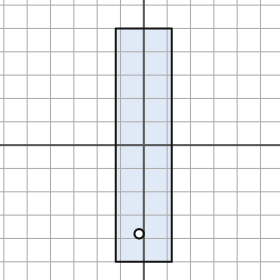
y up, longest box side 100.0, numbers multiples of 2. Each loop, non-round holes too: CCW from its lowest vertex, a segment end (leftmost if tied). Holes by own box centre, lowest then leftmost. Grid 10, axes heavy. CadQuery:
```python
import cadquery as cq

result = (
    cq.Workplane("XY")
    .moveTo(-12.0, -50.0)
    .lineTo(12.0, -50.0)
    .lineTo(12.0, 50.0)
    .lineTo(-12.0, 50.0)
    .close()
    .moveTo(-2.0, -38.0)
    .circle(2.0)
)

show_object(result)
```